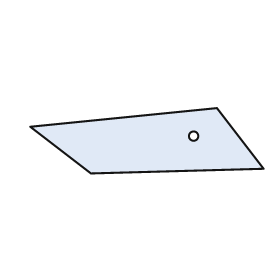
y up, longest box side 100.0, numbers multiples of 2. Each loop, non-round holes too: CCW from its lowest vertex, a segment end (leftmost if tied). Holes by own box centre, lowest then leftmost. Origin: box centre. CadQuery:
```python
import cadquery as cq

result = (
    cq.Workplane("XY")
    .moveTo(-24.0, -14.0)
    .lineTo(50.0, -12.0)
    .lineTo(30.0, 14.0)
    .lineTo(-50.0, 6.0)
    .close()
    .moveTo(20.0, 2.0)
    .circle(2.0)
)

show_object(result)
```